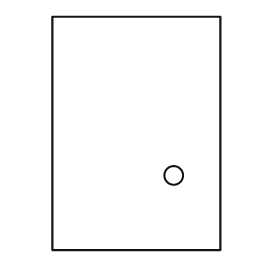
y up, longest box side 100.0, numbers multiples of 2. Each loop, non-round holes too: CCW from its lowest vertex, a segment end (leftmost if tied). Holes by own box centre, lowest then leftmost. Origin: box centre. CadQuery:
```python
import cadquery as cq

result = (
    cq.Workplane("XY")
    .moveTo(-36.0, -50.0)
    .lineTo(36.0, -50.0)
    .lineTo(36.0, 50.0)
    .lineTo(-36.0, 50.0)
    .close()
    .moveTo(16.0, -18.0)
    .circle(4.0)
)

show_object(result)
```